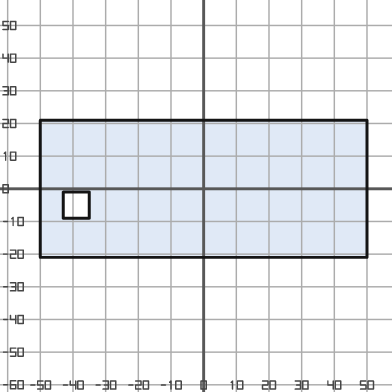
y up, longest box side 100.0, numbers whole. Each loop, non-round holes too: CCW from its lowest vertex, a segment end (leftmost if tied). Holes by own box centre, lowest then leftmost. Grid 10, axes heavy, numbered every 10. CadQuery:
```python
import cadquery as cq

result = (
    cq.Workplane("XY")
    .moveTo(-50.0, -21.0)
    .lineTo(50.0, -21.0)
    .lineTo(50.0, 21.0)
    .lineTo(-50.0, 21.0)
    .close()
    .moveTo(-43.0, -9.0)
    .lineTo(-35.0, -9.0)
    .lineTo(-35.0, -1.0)
    .lineTo(-43.0, -1.0)
    .close()
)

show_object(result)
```